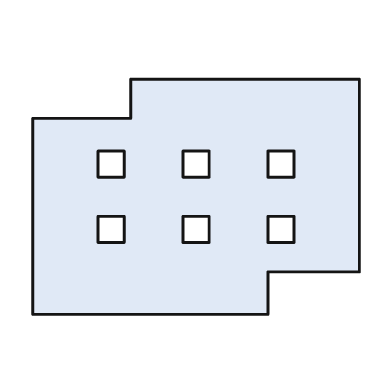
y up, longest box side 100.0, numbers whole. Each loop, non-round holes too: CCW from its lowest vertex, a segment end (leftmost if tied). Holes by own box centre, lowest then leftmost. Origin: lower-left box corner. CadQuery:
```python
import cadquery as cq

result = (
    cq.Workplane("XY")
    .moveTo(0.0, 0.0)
    .lineTo(72.0, 0.0)
    .lineTo(72.0, 13.0)
    .lineTo(100.0, 13.0)
    .lineTo(100.0, 72.0)
    .lineTo(30.0, 72.0)
    .lineTo(30.0, 60.0)
    .lineTo(0.0, 60.0)
    .close()
    .moveTo(20.0, 22.0)
    .lineTo(28.0, 22.0)
    .lineTo(28.0, 30.0)
    .lineTo(20.0, 30.0)
    .close()
    .moveTo(46.0, 22.0)
    .lineTo(54.0, 22.0)
    .lineTo(54.0, 30.0)
    .lineTo(46.0, 30.0)
    .close()
    .moveTo(72.0, 22.0)
    .lineTo(80.0, 22.0)
    .lineTo(80.0, 30.0)
    .lineTo(72.0, 30.0)
    .close()
    .moveTo(20.0, 42.0)
    .lineTo(28.0, 42.0)
    .lineTo(28.0, 50.0)
    .lineTo(20.0, 50.0)
    .close()
    .moveTo(46.0, 42.0)
    .lineTo(54.0, 42.0)
    .lineTo(54.0, 50.0)
    .lineTo(46.0, 50.0)
    .close()
    .moveTo(72.0, 42.0)
    .lineTo(80.0, 42.0)
    .lineTo(80.0, 50.0)
    .lineTo(72.0, 50.0)
    .close()
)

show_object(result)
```